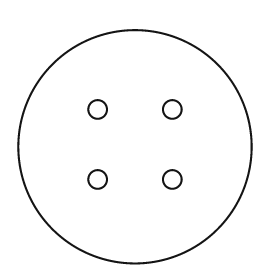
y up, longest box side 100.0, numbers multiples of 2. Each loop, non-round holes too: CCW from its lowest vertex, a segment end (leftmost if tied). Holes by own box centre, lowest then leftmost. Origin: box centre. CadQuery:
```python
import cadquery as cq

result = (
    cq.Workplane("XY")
    .moveTo(0.0, 0.0)
    .circle(50.0)
    .moveTo(-16.0, -14.0)
    .circle(4.0)
    .moveTo(16.0, -14.0)
    .circle(4.0)
    .moveTo(-16.0, 16.0)
    .circle(4.0)
    .moveTo(16.0, 16.0)
    .circle(4.0)
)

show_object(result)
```